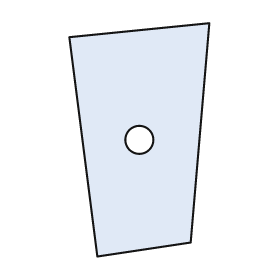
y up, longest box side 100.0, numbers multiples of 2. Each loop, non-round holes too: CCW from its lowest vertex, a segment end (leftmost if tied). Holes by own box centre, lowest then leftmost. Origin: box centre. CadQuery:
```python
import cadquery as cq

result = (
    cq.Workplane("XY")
    .moveTo(-18.0, -50.0)
    .lineTo(22.0, -44.0)
    .lineTo(30.0, 50.0)
    .lineTo(-30.0, 44.0)
    .close()
    .moveTo(0.0, 0.0)
    .circle(6.0)
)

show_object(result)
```